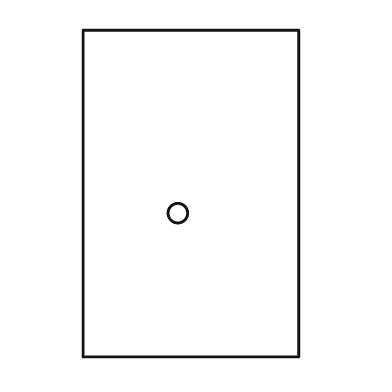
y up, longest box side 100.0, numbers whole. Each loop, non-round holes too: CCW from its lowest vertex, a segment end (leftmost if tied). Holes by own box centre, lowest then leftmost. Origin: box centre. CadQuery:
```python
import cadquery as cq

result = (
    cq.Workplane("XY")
    .moveTo(-33.0, -50.0)
    .lineTo(33.0, -50.0)
    .lineTo(33.0, 50.0)
    .lineTo(-33.0, 50.0)
    .close()
    .moveTo(-4.0, -6.0)
    .circle(3.0)
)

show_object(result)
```